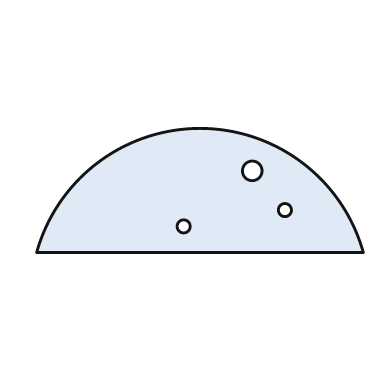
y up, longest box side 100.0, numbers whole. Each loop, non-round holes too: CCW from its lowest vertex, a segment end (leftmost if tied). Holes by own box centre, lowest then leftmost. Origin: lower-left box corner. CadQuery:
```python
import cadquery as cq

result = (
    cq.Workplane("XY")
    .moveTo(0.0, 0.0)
    .lineTo(100.0, 0.0)
    .threePointArc((50.0, 38.0), (0.0, 0.0))
    .close()
    .moveTo(45.0, 8.0)
    .circle(2.0)
    .moveTo(76.0, 13.0)
    .circle(2.0)
    .moveTo(66.0, 25.0)
    .circle(3.0)
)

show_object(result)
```